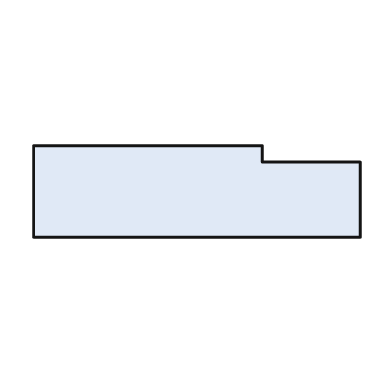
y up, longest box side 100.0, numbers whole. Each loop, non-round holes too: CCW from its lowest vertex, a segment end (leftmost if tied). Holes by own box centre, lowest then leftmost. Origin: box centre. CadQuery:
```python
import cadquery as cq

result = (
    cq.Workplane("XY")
    .moveTo(-50.0, -14.0)
    .lineTo(50.0, -14.0)
    .lineTo(50.0, 9.0)
    .lineTo(20.0, 9.0)
    .lineTo(20.0, 14.0)
    .lineTo(-50.0, 14.0)
    .close()
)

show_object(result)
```